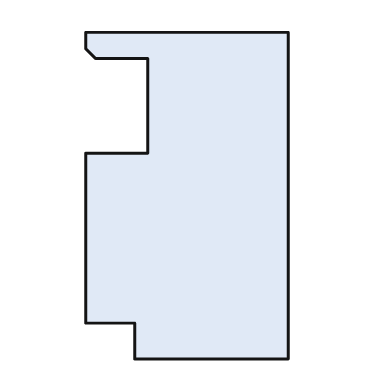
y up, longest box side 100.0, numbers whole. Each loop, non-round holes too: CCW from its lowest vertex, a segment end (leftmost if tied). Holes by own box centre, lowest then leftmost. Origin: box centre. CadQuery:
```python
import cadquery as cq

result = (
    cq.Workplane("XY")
    .moveTo(-16.0, -50.0)
    .lineTo(31.0, -50.0)
    .lineTo(31.0, 50.0)
    .lineTo(-31.0, 50.0)
    .lineTo(-31.0, 45.0)
    .lineTo(-28.0, 42.0)
    .lineTo(-12.0, 42.0)
    .lineTo(-12.0, 13.0)
    .lineTo(-31.0, 13.0)
    .lineTo(-31.0, -39.0)
    .lineTo(-16.0, -39.0)
    .close()
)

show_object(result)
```